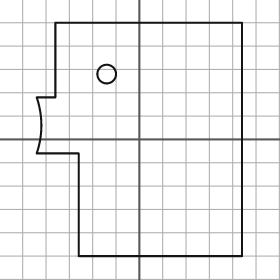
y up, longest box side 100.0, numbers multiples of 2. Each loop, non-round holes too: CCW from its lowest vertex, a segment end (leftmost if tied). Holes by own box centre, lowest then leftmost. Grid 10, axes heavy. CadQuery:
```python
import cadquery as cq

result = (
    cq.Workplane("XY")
    .moveTo(-26.0, -50.0)
    .lineTo(44.0, -50.0)
    .lineTo(44.0, 50.0)
    .lineTo(-36.0, 50.0)
    .lineTo(-36.0, 18.0)
    .lineTo(-44.0, 18.0)
    .threePointArc((-42.0, 6.0), (-44.0, -6.0))
    .lineTo(-26.0, -6.0)
    .close()
    .moveTo(-14.0, 28.0)
    .circle(4.0)
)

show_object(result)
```